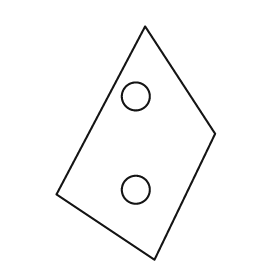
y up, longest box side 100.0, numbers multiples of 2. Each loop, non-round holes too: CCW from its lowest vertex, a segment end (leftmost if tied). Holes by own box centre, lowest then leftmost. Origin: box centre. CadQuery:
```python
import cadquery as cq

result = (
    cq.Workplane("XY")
    .moveTo(8.0, -50.0)
    .lineTo(34.0, 4.0)
    .lineTo(4.0, 50.0)
    .lineTo(-34.0, -22.0)
    .close()
    .moveTo(0.0, -20.0)
    .circle(6.0)
    .moveTo(0.0, 20.0)
    .circle(6.0)
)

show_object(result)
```